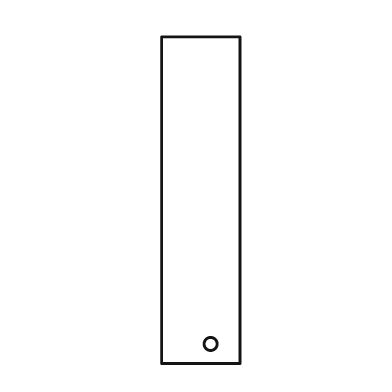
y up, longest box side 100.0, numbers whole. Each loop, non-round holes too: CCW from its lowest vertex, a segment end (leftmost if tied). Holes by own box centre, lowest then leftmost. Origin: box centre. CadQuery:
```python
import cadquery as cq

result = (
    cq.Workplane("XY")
    .moveTo(-12.0, -50.0)
    .lineTo(12.0, -50.0)
    .lineTo(12.0, 50.0)
    .lineTo(-12.0, 50.0)
    .close()
    .moveTo(3.0, -44.0)
    .circle(2.0)
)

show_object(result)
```